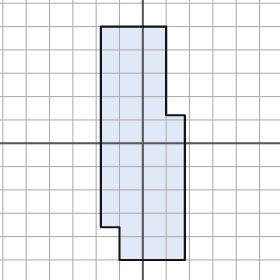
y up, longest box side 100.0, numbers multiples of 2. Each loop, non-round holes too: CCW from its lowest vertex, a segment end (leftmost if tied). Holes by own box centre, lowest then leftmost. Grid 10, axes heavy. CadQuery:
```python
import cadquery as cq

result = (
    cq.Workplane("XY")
    .moveTo(-10.0, -50.0)
    .lineTo(18.0, -50.0)
    .lineTo(18.0, 12.0)
    .lineTo(10.0, 12.0)
    .lineTo(10.0, 50.0)
    .lineTo(-18.0, 50.0)
    .lineTo(-18.0, -36.0)
    .lineTo(-10.0, -36.0)
    .close()
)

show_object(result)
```